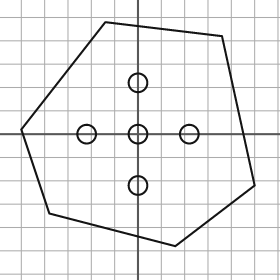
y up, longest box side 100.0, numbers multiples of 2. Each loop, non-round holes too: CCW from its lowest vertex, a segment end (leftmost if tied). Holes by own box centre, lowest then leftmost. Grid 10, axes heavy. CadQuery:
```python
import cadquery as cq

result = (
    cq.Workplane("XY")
    .moveTo(16.0, -48.0)
    .lineTo(50.0, -22.0)
    .lineTo(36.0, 42.0)
    .lineTo(-14.0, 48.0)
    .lineTo(-50.0, 2.0)
    .lineTo(-38.0, -34.0)
    .close()
    .moveTo(0.0, -22.0)
    .circle(4.0)
    .moveTo(-22.0, 0.0)
    .circle(4.0)
    .moveTo(0.0, 0.0)
    .circle(4.0)
    .moveTo(22.0, 0.0)
    .circle(4.0)
    .moveTo(0.0, 22.0)
    .circle(4.0)
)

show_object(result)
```